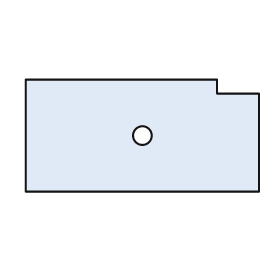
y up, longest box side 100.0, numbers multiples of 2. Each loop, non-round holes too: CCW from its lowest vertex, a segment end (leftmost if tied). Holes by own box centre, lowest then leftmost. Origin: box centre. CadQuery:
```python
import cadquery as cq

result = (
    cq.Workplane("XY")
    .moveTo(-50.0, -24.0)
    .lineTo(50.0, -24.0)
    .lineTo(50.0, 18.0)
    .lineTo(32.0, 18.0)
    .lineTo(32.0, 24.0)
    .lineTo(-50.0, 24.0)
    .close()
    .moveTo(0.0, 0.0)
    .circle(4.0)
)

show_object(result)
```